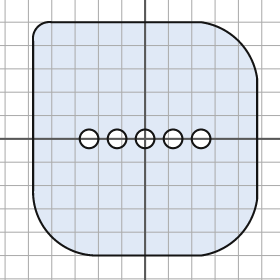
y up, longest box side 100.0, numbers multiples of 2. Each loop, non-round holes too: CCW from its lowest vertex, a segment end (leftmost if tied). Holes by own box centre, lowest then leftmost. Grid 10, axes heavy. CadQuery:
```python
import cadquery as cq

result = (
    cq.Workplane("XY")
    .moveTo(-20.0, -50.0)
    .lineTo(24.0, -50.0)
    .threePointArc((40.0, -42.0), (48.0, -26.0))
    .lineTo(48.0, 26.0)
    .threePointArc((40.0, 42.0), (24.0, 50.0))
    .lineTo(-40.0, 50.0)
    .threePointArc((-46.0, 48.0), (-48.0, 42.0))
    .lineTo(-48.0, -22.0)
    .threePointArc((-40.0, -42.0), (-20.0, -50.0))
    .close()
    .moveTo(-24.0, 0.0)
    .circle(4.0)
    .moveTo(-12.0, 0.0)
    .circle(4.0)
    .moveTo(0.0, 0.0)
    .circle(4.0)
    .moveTo(12.0, 0.0)
    .circle(4.0)
    .moveTo(24.0, 0.0)
    .circle(4.0)
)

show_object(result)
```